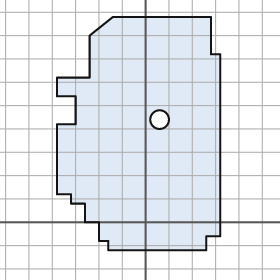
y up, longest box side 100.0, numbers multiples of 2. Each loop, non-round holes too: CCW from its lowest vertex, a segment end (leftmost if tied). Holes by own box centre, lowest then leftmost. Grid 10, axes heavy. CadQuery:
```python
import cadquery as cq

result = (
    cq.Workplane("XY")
    .moveTo(-16.0, -12.0)
    .lineTo(26.0, -12.0)
    .lineTo(26.0, -6.0)
    .lineTo(32.0, -6.0)
    .lineTo(32.0, 72.0)
    .lineTo(28.0, 72.0)
    .lineTo(28.0, 88.0)
    .lineTo(-14.0, 88.0)
    .lineTo(-24.0, 80.0)
    .lineTo(-24.0, 62.0)
    .lineTo(-38.0, 62.0)
    .lineTo(-38.0, 54.0)
    .lineTo(-30.0, 54.0)
    .lineTo(-30.0, 42.0)
    .lineTo(-38.0, 42.0)
    .lineTo(-38.0, 12.0)
    .lineTo(-32.0, 12.0)
    .lineTo(-32.0, 8.0)
    .lineTo(-26.0, 8.0)
    .lineTo(-26.0, 0.0)
    .lineTo(-20.0, 0.0)
    .lineTo(-20.0, -8.0)
    .lineTo(-16.0, -8.0)
    .close()
    .moveTo(6.0, 44.0)
    .circle(4.0)
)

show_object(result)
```